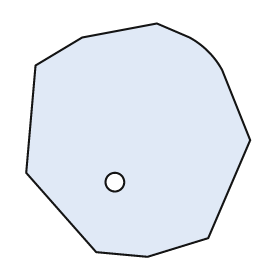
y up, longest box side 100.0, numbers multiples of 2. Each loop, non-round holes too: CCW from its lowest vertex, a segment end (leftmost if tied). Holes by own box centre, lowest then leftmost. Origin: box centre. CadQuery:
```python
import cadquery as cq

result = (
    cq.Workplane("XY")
    .moveTo(4.0, -50.0)
    .lineTo(30.0, -42.0)
    .lineTo(48.0, 0.0)
    .lineTo(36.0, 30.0)
    .threePointArc((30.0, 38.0), (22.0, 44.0))
    .lineTo(8.0, 50.0)
    .lineTo(-24.0, 44.0)
    .lineTo(-44.0, 32.0)
    .lineTo(-48.0, -14.0)
    .lineTo(-18.0, -48.0)
    .close()
    .moveTo(-10.0, -18.0)
    .circle(4.0)
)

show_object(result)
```